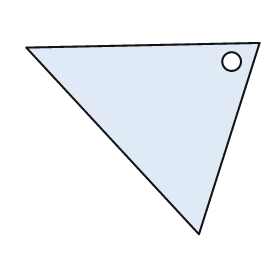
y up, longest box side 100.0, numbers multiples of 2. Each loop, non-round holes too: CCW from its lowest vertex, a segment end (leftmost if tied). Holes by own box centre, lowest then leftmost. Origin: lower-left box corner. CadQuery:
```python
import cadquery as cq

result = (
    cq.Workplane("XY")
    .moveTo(74.0, 0.0)
    .lineTo(100.0, 82.0)
    .lineTo(0.0, 80.0)
    .close()
    .moveTo(88.0, 74.0)
    .circle(4.0)
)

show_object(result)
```